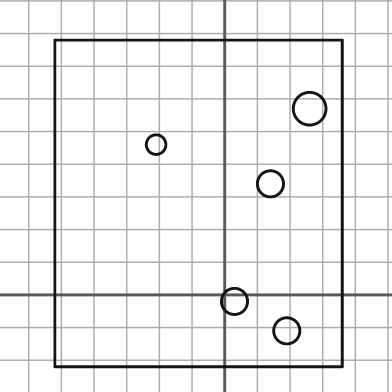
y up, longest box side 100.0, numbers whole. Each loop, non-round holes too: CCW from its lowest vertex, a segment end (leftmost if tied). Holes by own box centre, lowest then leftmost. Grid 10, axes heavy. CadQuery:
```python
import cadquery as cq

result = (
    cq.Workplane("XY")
    .moveTo(-52.0, -22.0)
    .lineTo(36.0, -22.0)
    .lineTo(36.0, 78.0)
    .lineTo(-52.0, 78.0)
    .close()
    .moveTo(19.0, -11.0)
    .circle(4.0)
    .moveTo(3.0, -2.0)
    .circle(4.0)
    .moveTo(14.0, 34.0)
    .circle(4.0)
    .moveTo(-21.0, 46.0)
    .circle(3.0)
    .moveTo(26.0, 57.0)
    .circle(5.0)
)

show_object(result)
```